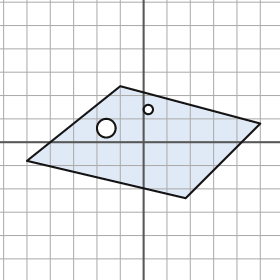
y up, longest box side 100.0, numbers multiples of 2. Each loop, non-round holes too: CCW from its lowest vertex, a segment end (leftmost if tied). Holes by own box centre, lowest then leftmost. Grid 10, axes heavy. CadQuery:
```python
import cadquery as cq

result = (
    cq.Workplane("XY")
    .moveTo(18.0, -24.0)
    .lineTo(50.0, 8.0)
    .lineTo(-10.0, 24.0)
    .lineTo(-50.0, -8.0)
    .close()
    .moveTo(-16.0, 6.0)
    .circle(4.0)
    .moveTo(2.0, 14.0)
    .circle(2.0)
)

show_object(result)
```